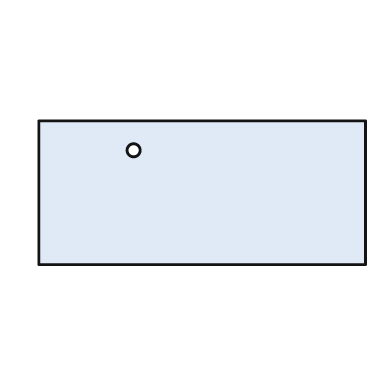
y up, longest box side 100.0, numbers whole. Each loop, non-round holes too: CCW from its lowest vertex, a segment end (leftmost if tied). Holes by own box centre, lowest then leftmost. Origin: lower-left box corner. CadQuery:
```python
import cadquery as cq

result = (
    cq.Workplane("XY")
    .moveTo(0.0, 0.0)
    .lineTo(100.0, 0.0)
    .lineTo(100.0, 44.0)
    .lineTo(0.0, 44.0)
    .close()
    .moveTo(29.0, 35.0)
    .circle(2.0)
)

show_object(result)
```